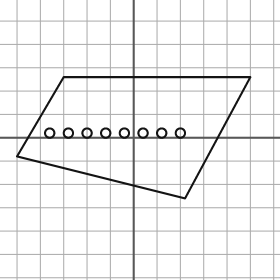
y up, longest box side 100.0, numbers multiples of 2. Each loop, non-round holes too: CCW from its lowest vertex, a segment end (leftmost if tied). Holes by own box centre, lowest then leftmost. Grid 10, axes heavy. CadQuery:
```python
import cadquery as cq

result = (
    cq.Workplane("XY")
    .moveTo(22.0, -26.0)
    .lineTo(50.0, 26.0)
    .lineTo(-30.0, 26.0)
    .lineTo(-50.0, -8.0)
    .close()
    .moveTo(-36.0, 2.0)
    .circle(2.0)
    .moveTo(-28.0, 2.0)
    .circle(2.0)
    .moveTo(-20.0, 2.0)
    .circle(2.0)
    .moveTo(-12.0, 2.0)
    .circle(2.0)
    .moveTo(-4.0, 2.0)
    .circle(2.0)
    .moveTo(4.0, 2.0)
    .circle(2.0)
    .moveTo(12.0, 2.0)
    .circle(2.0)
    .moveTo(20.0, 2.0)
    .circle(2.0)
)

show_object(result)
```